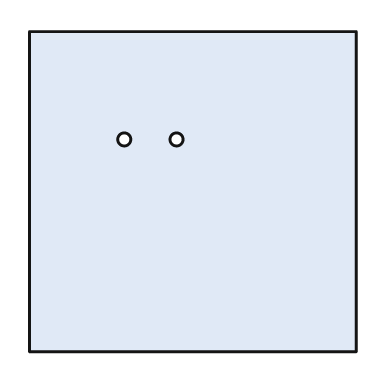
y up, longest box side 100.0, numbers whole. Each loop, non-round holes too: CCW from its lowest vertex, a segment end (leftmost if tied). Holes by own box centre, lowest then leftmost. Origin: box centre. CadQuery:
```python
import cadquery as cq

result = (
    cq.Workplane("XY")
    .moveTo(-50.0, -49.0)
    .lineTo(50.0, -49.0)
    .lineTo(50.0, 49.0)
    .lineTo(-50.0, 49.0)
    .close()
    .moveTo(-21.0, 16.0)
    .circle(2.0)
    .moveTo(-5.0, 16.0)
    .circle(2.0)
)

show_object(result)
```